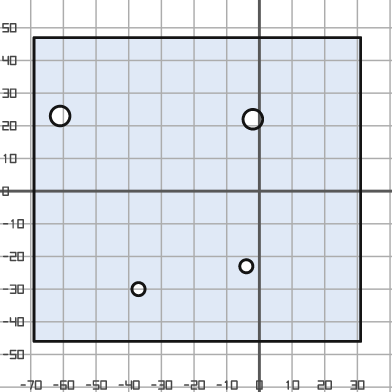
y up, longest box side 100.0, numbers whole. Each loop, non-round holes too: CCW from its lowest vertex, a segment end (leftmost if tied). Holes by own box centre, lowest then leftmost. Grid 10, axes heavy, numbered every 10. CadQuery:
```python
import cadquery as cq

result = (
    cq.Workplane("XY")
    .moveTo(-69.0, -46.0)
    .lineTo(31.0, -46.0)
    .lineTo(31.0, 47.0)
    .lineTo(-69.0, 47.0)
    .close()
    .moveTo(-37.0, -30.0)
    .circle(2.0)
    .moveTo(-4.0, -23.0)
    .circle(2.0)
    .moveTo(-2.0, 22.0)
    .circle(3.0)
    .moveTo(-61.0, 23.0)
    .circle(3.0)
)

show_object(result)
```